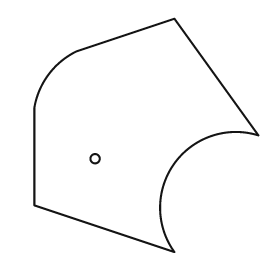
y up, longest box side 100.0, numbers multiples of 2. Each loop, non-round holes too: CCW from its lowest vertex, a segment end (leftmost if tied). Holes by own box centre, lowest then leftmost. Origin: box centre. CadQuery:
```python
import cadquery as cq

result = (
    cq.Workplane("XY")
    .moveTo(12.0, -50.0)
    .threePointArc((12.0, -12.0), (48.0, 0.0))
    .lineTo(12.0, 50.0)
    .lineTo(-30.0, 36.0)
    .threePointArc((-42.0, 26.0), (-48.0, 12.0))
    .lineTo(-48.0, -30.0)
    .close()
    .moveTo(-22.0, -10.0)
    .circle(2.0)
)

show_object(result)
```